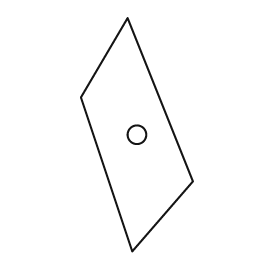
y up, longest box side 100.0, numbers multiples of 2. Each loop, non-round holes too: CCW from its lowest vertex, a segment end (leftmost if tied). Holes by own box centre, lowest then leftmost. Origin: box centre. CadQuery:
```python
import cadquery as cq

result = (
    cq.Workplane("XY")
    .moveTo(-2.0, -50.0)
    .lineTo(24.0, -20.0)
    .lineTo(-4.0, 50.0)
    .lineTo(-24.0, 16.0)
    .close()
    .moveTo(0.0, 0.0)
    .circle(4.0)
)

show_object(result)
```